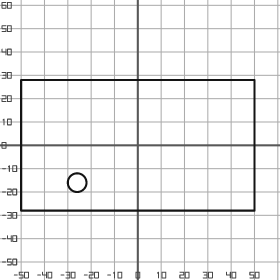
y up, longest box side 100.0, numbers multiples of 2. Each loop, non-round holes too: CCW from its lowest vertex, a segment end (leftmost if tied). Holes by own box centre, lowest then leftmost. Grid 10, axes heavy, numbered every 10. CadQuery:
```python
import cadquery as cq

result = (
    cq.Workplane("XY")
    .moveTo(-50.0, -28.0)
    .lineTo(50.0, -28.0)
    .lineTo(50.0, 28.0)
    .lineTo(-50.0, 28.0)
    .close()
    .moveTo(-26.0, -16.0)
    .circle(4.0)
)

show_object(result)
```